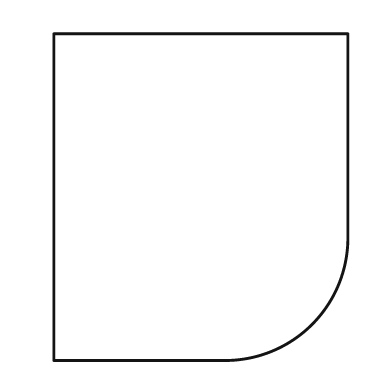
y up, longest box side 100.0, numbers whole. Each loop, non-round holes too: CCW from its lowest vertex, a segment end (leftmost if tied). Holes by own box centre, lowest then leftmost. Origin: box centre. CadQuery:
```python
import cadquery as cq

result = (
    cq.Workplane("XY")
    .moveTo(-45.0, -50.0)
    .lineTo(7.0, -50.0)
    .threePointArc((34.0, -39.0), (45.0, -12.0))
    .lineTo(45.0, 50.0)
    .lineTo(-45.0, 50.0)
    .close()
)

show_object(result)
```